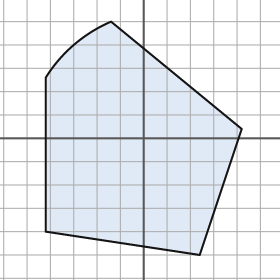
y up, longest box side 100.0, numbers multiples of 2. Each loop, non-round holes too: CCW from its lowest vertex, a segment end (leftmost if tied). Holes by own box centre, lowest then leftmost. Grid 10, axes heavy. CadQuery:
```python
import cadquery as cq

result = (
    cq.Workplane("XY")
    .moveTo(24.0, -50.0)
    .lineTo(42.0, 4.0)
    .lineTo(-14.0, 50.0)
    .threePointArc((-30.0, 40.0), (-42.0, 26.0))
    .lineTo(-42.0, -40.0)
    .close()
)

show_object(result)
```